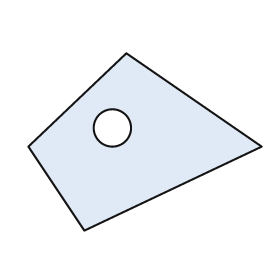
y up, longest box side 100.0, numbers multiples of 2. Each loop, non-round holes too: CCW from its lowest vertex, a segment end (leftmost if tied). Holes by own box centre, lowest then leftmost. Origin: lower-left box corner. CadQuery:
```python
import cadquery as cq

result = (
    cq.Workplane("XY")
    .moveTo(24.0, 0.0)
    .lineTo(100.0, 36.0)
    .lineTo(42.0, 76.0)
    .lineTo(0.0, 36.0)
    .close()
    .moveTo(36.0, 44.0)
    .circle(8.0)
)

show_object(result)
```